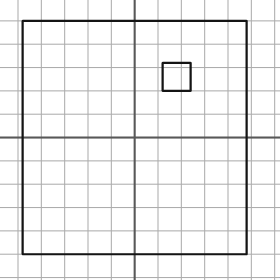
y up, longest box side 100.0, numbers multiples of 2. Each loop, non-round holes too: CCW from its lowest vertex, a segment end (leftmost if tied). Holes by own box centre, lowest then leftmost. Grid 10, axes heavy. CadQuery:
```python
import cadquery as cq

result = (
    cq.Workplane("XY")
    .moveTo(-48.0, -50.0)
    .lineTo(48.0, -50.0)
    .lineTo(48.0, 50.0)
    .lineTo(-48.0, 50.0)
    .close()
    .moveTo(12.0, 20.0)
    .lineTo(24.0, 20.0)
    .lineTo(24.0, 32.0)
    .lineTo(12.0, 32.0)
    .close()
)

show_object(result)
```